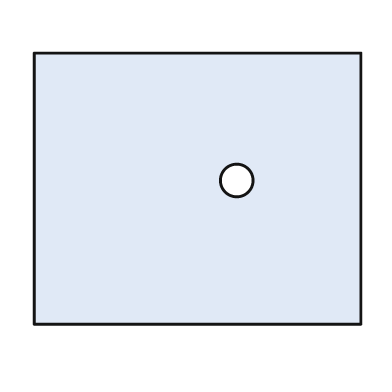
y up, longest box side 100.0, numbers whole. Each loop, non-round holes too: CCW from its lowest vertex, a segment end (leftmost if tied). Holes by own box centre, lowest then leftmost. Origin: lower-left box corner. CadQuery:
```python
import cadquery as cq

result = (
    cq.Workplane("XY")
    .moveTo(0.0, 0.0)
    .lineTo(100.0, 0.0)
    .lineTo(100.0, 83.0)
    .lineTo(0.0, 83.0)
    .close()
    .moveTo(62.0, 44.0)
    .circle(5.0)
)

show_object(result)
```